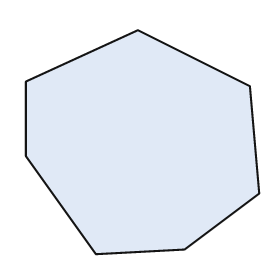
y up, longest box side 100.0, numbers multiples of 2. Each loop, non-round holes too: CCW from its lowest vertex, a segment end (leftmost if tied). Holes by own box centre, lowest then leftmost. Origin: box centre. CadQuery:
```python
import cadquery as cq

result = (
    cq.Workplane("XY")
    .moveTo(-20.0, -48.0)
    .lineTo(18.0, -46.0)
    .lineTo(50.0, -22.0)
    .lineTo(46.0, 24.0)
    .lineTo(-2.0, 48.0)
    .lineTo(-50.0, 26.0)
    .lineTo(-50.0, -6.0)
    .close()
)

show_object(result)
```